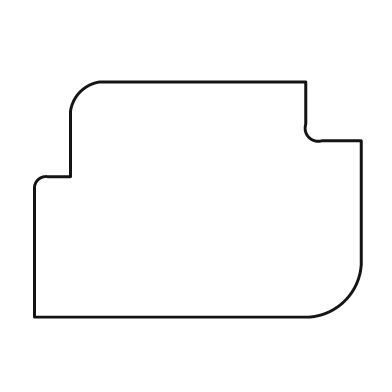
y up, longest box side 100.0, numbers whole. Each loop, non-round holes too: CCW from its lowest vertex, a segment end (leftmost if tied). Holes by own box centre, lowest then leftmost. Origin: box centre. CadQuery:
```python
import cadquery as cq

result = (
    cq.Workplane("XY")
    .moveTo(-50.0, -36.0)
    .lineTo(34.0, -36.0)
    .threePointArc((45.0, -31.0), (50.0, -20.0))
    .lineTo(50.0, 18.0)
    .lineTo(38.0, 18.0)
    .threePointArc((34.0, 19.0), (33.0, 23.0))
    .lineTo(33.0, 36.0)
    .lineTo(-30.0, 36.0)
    .threePointArc((-36.0, 33.0), (-39.0, 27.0))
    .lineTo(-39.0, 7.0)
    .lineTo(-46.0, 7.0)
    .threePointArc((-49.0, 6.0), (-50.0, 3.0))
    .close()
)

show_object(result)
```